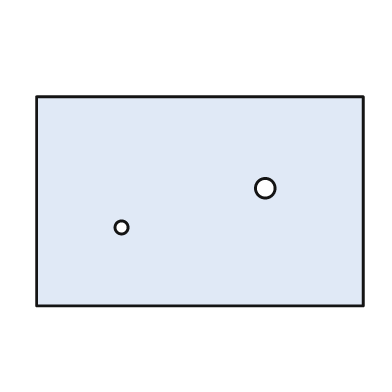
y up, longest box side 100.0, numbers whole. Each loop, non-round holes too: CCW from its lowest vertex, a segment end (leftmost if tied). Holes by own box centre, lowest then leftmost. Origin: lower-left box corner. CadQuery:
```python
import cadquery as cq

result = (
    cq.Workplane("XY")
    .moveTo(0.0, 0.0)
    .lineTo(100.0, 0.0)
    .lineTo(100.0, 64.0)
    .lineTo(0.0, 64.0)
    .close()
    .moveTo(26.0, 24.0)
    .circle(2.0)
    .moveTo(70.0, 36.0)
    .circle(3.0)
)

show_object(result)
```